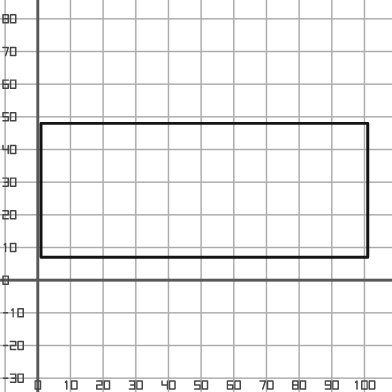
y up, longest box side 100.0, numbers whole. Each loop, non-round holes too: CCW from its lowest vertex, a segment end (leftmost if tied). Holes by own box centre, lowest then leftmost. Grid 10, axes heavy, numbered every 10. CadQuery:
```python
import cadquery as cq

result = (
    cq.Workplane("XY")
    .moveTo(1.0, 7.0)
    .lineTo(101.0, 7.0)
    .lineTo(101.0, 48.0)
    .lineTo(1.0, 48.0)
    .close()
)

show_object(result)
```